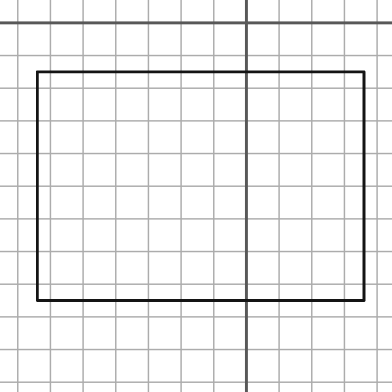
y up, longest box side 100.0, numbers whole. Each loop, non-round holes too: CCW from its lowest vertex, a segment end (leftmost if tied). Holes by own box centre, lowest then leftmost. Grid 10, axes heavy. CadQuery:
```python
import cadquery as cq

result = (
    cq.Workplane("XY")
    .moveTo(-64.0, -85.0)
    .lineTo(36.0, -85.0)
    .lineTo(36.0, -15.0)
    .lineTo(-64.0, -15.0)
    .close()
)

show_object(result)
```